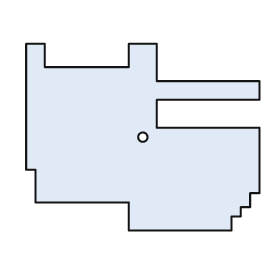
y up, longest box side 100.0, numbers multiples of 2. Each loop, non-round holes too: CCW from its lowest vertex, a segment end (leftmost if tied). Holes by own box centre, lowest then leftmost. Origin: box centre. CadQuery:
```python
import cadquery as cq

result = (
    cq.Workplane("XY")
    .moveTo(-6.0, -40.0)
    .lineTo(38.0, -40.0)
    .lineTo(38.0, -34.0)
    .lineTo(42.0, -34.0)
    .lineTo(42.0, -30.0)
    .lineTo(46.0, -30.0)
    .lineTo(46.0, -24.0)
    .lineTo(50.0, -24.0)
    .lineTo(50.0, 4.0)
    .lineTo(6.0, 4.0)
    .lineTo(6.0, 16.0)
    .lineTo(50.0, 16.0)
    .lineTo(50.0, 24.0)
    .lineTo(6.0, 24.0)
    .lineTo(6.0, 40.0)
    .lineTo(-6.0, 40.0)
    .lineTo(-6.0, 30.0)
    .lineTo(-42.0, 30.0)
    .lineTo(-42.0, 40.0)
    .lineTo(-50.0, 40.0)
    .lineTo(-50.0, -14.0)
    .lineTo(-46.0, -14.0)
    .lineTo(-46.0, -28.0)
    .lineTo(-6.0, -28.0)
    .close()
    .moveTo(0.0, 0.0)
    .circle(2.0)
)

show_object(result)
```